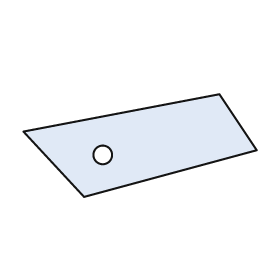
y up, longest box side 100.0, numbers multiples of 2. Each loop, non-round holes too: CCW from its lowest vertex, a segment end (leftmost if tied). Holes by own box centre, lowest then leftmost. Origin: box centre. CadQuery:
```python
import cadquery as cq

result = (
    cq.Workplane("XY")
    .moveTo(-24.0, -22.0)
    .lineTo(50.0, -2.0)
    .lineTo(34.0, 22.0)
    .lineTo(-50.0, 6.0)
    .close()
    .moveTo(-16.0, -4.0)
    .circle(4.0)
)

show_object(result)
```